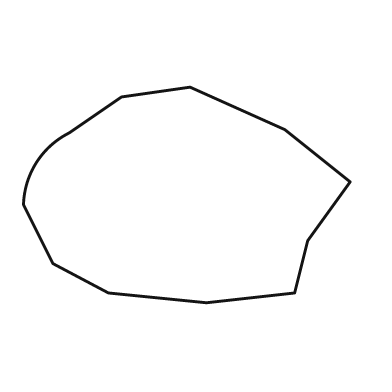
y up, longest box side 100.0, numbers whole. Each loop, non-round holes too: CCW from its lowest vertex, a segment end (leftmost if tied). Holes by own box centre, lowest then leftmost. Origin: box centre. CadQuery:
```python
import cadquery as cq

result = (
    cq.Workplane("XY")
    .moveTo(6.0, -33.0)
    .lineTo(33.0, -30.0)
    .lineTo(37.0, -14.0)
    .lineTo(50.0, 4.0)
    .lineTo(30.0, 20.0)
    .lineTo(1.0, 33.0)
    .lineTo(-20.0, 30.0)
    .lineTo(-36.0, 19.0)
    .threePointArc((-46.0, 10.0), (-50.0, -3.0))
    .lineTo(-41.0, -21.0)
    .lineTo(-24.0, -30.0)
    .close()
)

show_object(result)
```